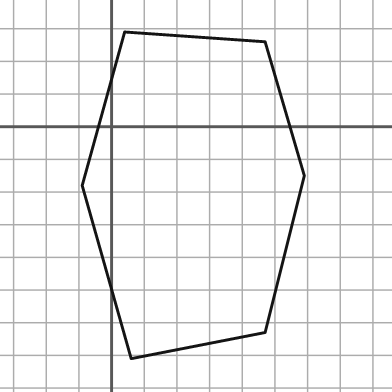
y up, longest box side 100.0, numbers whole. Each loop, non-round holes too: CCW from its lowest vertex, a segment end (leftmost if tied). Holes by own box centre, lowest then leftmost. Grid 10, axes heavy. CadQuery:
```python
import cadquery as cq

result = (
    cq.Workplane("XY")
    .moveTo(6.0, -71.0)
    .lineTo(47.0, -63.0)
    .lineTo(59.0, -15.0)
    .lineTo(47.0, 26.0)
    .lineTo(4.0, 29.0)
    .lineTo(-9.0, -18.0)
    .close()
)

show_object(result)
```